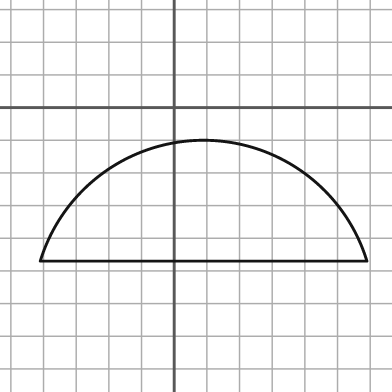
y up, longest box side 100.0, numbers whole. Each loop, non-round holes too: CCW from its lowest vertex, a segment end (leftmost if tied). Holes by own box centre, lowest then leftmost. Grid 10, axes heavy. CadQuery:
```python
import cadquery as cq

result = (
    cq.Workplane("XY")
    .moveTo(-41.0, -47.0)
    .lineTo(59.0, -47.0)
    .threePointArc((9.0, -10.0), (-41.0, -47.0))
    .close()
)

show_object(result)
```